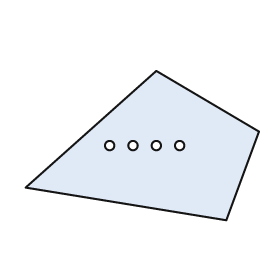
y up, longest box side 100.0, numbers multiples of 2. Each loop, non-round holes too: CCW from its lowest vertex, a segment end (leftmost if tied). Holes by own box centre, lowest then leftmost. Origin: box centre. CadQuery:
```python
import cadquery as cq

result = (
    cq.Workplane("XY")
    .moveTo(36.0, -32.0)
    .lineTo(50.0, 6.0)
    .lineTo(6.0, 32.0)
    .lineTo(-50.0, -18.0)
    .close()
    .moveTo(-14.0, 0.0)
    .circle(2.0)
    .moveTo(-4.0, 0.0)
    .circle(2.0)
    .moveTo(6.0, 0.0)
    .circle(2.0)
    .moveTo(16.0, 0.0)
    .circle(2.0)
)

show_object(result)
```